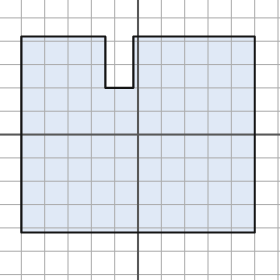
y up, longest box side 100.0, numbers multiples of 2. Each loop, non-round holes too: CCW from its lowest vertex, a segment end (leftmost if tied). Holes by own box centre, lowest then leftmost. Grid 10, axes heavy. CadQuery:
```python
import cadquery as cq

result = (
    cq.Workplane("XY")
    .moveTo(-50.0, -42.0)
    .lineTo(50.0, -42.0)
    .lineTo(50.0, 42.0)
    .lineTo(-2.0, 42.0)
    .lineTo(-2.0, 20.0)
    .lineTo(-14.0, 20.0)
    .lineTo(-14.0, 42.0)
    .lineTo(-50.0, 42.0)
    .close()
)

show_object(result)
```